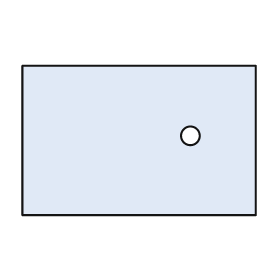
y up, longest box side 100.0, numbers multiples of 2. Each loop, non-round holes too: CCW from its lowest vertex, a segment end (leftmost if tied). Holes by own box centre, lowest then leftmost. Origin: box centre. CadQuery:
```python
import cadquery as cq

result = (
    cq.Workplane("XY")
    .moveTo(-50.0, -32.0)
    .lineTo(50.0, -32.0)
    .lineTo(50.0, 32.0)
    .lineTo(-50.0, 32.0)
    .close()
    .moveTo(22.0, 2.0)
    .circle(4.0)
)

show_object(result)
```